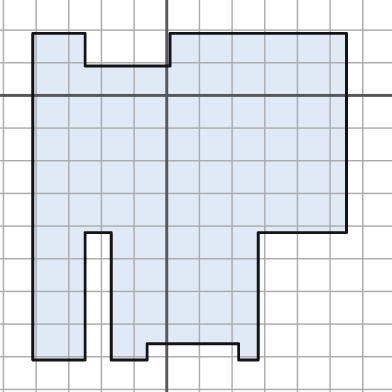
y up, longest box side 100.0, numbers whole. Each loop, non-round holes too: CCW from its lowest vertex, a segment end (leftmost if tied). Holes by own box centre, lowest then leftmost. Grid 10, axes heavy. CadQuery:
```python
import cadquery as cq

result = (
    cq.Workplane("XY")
    .moveTo(-41.0, -81.0)
    .lineTo(-25.0, -81.0)
    .lineTo(-25.0, -42.0)
    .lineTo(-17.0, -42.0)
    .lineTo(-17.0, -81.0)
    .lineTo(-6.0, -81.0)
    .lineTo(-6.0, -76.0)
    .lineTo(22.0, -76.0)
    .lineTo(22.0, -81.0)
    .lineTo(28.0, -81.0)
    .lineTo(28.0, -42.0)
    .lineTo(55.0, -42.0)
    .lineTo(55.0, 19.0)
    .lineTo(1.0, 19.0)
    .lineTo(1.0, 9.0)
    .lineTo(-25.0, 9.0)
    .lineTo(-25.0, 19.0)
    .lineTo(-41.0, 19.0)
    .close()
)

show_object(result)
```